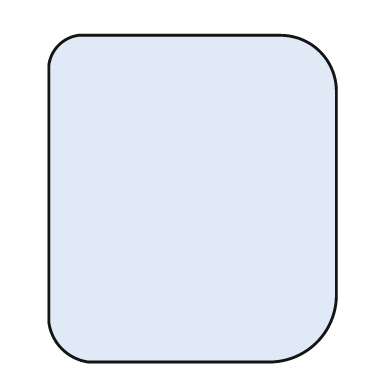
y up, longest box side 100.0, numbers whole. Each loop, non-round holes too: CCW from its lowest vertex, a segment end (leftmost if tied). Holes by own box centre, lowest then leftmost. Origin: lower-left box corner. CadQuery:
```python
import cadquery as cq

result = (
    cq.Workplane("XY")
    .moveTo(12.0, 0.0)
    .lineTo(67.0, 0.0)
    .threePointArc((82.0, 6.0), (88.0, 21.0))
    .lineTo(88.0, 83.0)
    .threePointArc((83.0, 95.0), (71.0, 100.0))
    .lineTo(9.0, 100.0)
    .threePointArc((3.0, 97.0), (0.0, 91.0))
    .lineTo(0.0, 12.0)
    .threePointArc((4.0, 4.0), (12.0, 0.0))
    .close()
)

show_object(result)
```